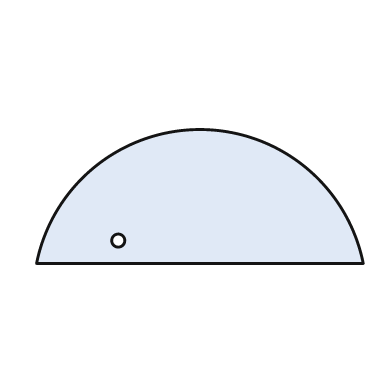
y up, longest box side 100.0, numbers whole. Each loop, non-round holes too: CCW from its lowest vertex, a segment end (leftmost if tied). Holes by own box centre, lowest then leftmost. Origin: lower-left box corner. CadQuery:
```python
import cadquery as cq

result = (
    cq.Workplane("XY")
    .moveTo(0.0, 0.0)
    .lineTo(100.0, 0.0)
    .threePointArc((50.0, 41.0), (0.0, 0.0))
    .close()
    .moveTo(25.0, 7.0)
    .circle(2.0)
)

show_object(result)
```